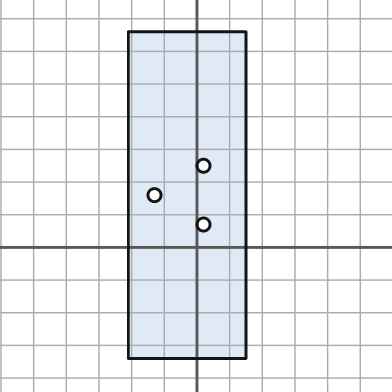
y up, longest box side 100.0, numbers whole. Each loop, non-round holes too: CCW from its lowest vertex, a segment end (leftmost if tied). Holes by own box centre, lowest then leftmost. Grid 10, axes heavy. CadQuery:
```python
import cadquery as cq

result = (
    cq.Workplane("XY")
    .moveTo(-21.0, -34.0)
    .lineTo(15.0, -34.0)
    .lineTo(15.0, 66.0)
    .lineTo(-21.0, 66.0)
    .close()
    .moveTo(2.0, 7.0)
    .circle(2.0)
    .moveTo(-13.0, 16.0)
    .circle(2.0)
    .moveTo(2.0, 25.0)
    .circle(2.0)
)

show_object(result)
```